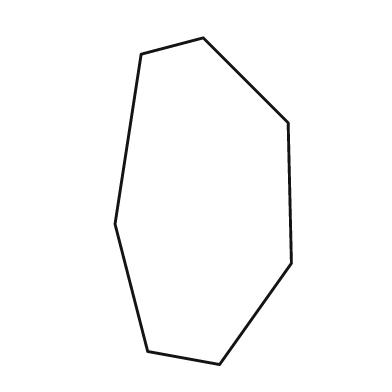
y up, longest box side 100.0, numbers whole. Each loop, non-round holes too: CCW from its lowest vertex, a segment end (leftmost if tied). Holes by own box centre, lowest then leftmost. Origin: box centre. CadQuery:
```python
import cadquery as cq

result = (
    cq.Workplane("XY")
    .moveTo(5.0, -50.0)
    .lineTo(27.0, -19.0)
    .lineTo(26.0, 24.0)
    .lineTo(0.0, 50.0)
    .lineTo(-19.0, 45.0)
    .lineTo(-27.0, -7.0)
    .lineTo(-17.0, -46.0)
    .close()
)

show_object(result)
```